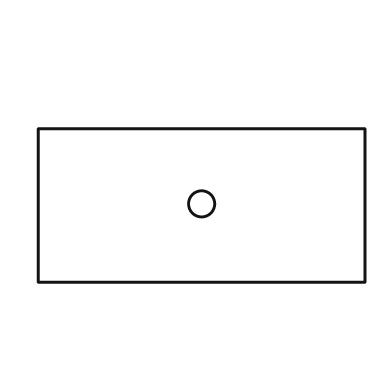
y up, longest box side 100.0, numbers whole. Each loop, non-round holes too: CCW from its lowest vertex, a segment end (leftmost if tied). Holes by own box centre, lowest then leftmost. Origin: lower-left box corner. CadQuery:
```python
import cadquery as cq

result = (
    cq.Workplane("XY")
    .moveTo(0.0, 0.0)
    .lineTo(100.0, 0.0)
    .lineTo(100.0, 47.0)
    .lineTo(0.0, 47.0)
    .close()
    .moveTo(50.0, 24.0)
    .circle(4.0)
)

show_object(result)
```